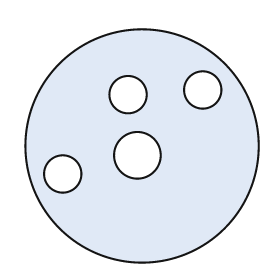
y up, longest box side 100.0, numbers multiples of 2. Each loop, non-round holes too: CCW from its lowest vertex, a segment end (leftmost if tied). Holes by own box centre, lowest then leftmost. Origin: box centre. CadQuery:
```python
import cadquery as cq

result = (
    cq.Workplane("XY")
    .moveTo(0.0, 0.0)
    .circle(50.0)
    .moveTo(-34.0, -12.0)
    .circle(8.0)
    .moveTo(-2.0, -4.0)
    .circle(10.0)
    .moveTo(-6.0, 22.0)
    .circle(8.0)
    .moveTo(26.0, 24.0)
    .circle(8.0)
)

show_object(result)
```